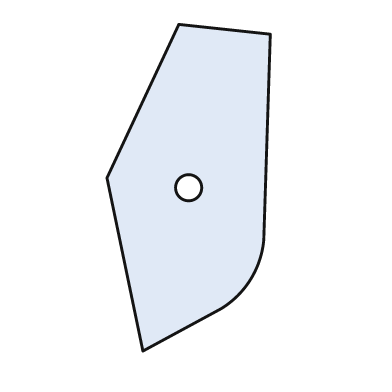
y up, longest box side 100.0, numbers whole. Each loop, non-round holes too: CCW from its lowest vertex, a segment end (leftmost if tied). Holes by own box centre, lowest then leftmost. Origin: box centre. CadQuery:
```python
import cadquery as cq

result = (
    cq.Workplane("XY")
    .moveTo(-14.0, -50.0)
    .lineTo(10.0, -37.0)
    .threePointArc((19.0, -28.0), (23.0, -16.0))
    .lineTo(25.0, 47.0)
    .lineTo(-3.0, 50.0)
    .lineTo(-25.0, 3.0)
    .close()
    .moveTo(0.0, 0.0)
    .circle(4.0)
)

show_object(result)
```